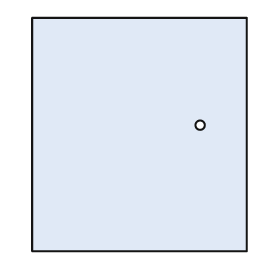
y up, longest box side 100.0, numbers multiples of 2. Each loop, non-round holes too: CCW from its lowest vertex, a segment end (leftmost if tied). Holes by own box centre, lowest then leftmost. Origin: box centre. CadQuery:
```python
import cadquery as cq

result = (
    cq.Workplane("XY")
    .moveTo(-46.0, -50.0)
    .lineTo(46.0, -50.0)
    .lineTo(46.0, 50.0)
    .lineTo(-46.0, 50.0)
    .close()
    .moveTo(26.0, 4.0)
    .circle(2.0)
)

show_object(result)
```